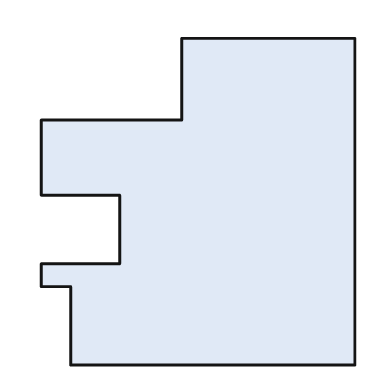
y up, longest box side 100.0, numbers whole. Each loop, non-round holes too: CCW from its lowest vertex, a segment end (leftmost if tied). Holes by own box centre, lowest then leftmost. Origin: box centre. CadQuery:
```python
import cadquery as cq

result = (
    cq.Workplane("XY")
    .moveTo(-39.0, -50.0)
    .lineTo(48.0, -50.0)
    .lineTo(48.0, 50.0)
    .lineTo(-5.0, 50.0)
    .lineTo(-5.0, 25.0)
    .lineTo(-48.0, 25.0)
    .lineTo(-48.0, 2.0)
    .lineTo(-24.0, 2.0)
    .lineTo(-24.0, -19.0)
    .lineTo(-48.0, -19.0)
    .lineTo(-48.0, -26.0)
    .lineTo(-39.0, -26.0)
    .close()
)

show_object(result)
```